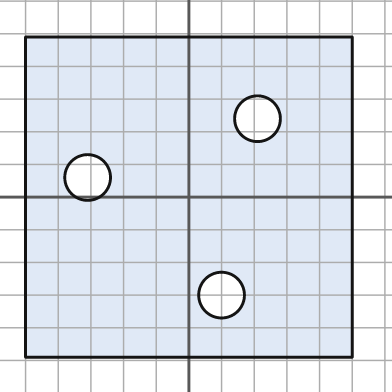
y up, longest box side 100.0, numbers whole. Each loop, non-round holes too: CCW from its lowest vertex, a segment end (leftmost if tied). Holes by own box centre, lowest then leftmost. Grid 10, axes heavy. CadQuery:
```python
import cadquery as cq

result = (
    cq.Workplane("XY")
    .moveTo(-50.0, -49.0)
    .lineTo(50.0, -49.0)
    .lineTo(50.0, 49.0)
    .lineTo(-50.0, 49.0)
    .close()
    .moveTo(10.0, -30.0)
    .circle(7.0)
    .moveTo(-31.0, 6.0)
    .circle(7.0)
    .moveTo(21.0, 24.0)
    .circle(7.0)
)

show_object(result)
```